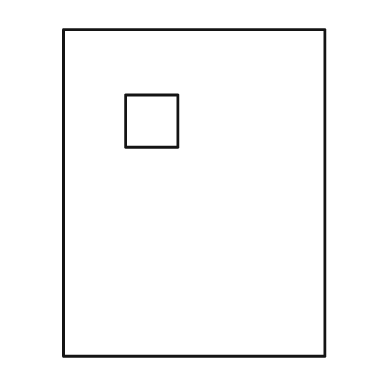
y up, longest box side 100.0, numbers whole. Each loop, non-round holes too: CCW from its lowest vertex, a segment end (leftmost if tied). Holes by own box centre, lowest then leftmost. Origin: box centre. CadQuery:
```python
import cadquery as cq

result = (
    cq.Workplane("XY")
    .moveTo(-40.0, -50.0)
    .lineTo(40.0, -50.0)
    .lineTo(40.0, 50.0)
    .lineTo(-40.0, 50.0)
    .close()
    .moveTo(-21.0, 14.0)
    .lineTo(-5.0, 14.0)
    .lineTo(-5.0, 30.0)
    .lineTo(-21.0, 30.0)
    .close()
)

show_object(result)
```